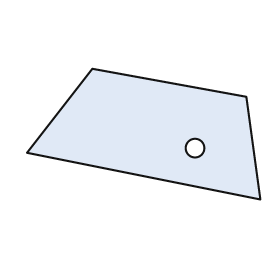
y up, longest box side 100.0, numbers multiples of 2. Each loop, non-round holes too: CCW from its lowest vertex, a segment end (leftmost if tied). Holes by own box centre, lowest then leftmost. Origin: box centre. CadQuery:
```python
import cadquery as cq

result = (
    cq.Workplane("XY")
    .moveTo(50.0, -28.0)
    .lineTo(44.0, 16.0)
    .lineTo(-22.0, 28.0)
    .lineTo(-50.0, -8.0)
    .close()
    .moveTo(22.0, -6.0)
    .circle(4.0)
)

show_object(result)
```